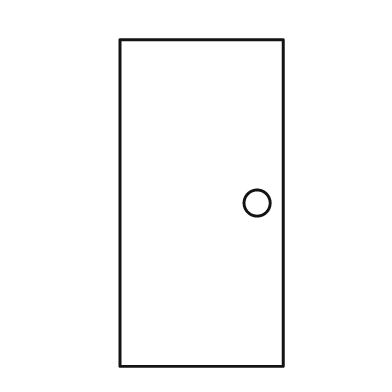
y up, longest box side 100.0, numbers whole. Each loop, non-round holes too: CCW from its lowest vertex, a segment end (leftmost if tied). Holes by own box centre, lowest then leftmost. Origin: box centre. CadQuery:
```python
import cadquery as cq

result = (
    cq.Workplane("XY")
    .moveTo(-25.0, -50.0)
    .lineTo(25.0, -50.0)
    .lineTo(25.0, 50.0)
    .lineTo(-25.0, 50.0)
    .close()
    .moveTo(17.0, 0.0)
    .circle(4.0)
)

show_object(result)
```